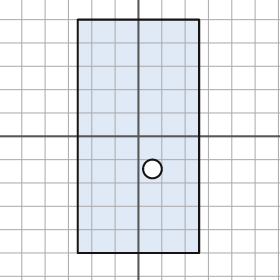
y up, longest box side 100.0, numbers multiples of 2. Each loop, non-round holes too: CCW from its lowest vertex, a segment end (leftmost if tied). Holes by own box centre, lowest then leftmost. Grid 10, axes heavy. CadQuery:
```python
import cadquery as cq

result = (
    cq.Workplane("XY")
    .moveTo(-26.0, -50.0)
    .lineTo(26.0, -50.0)
    .lineTo(26.0, 50.0)
    .lineTo(-26.0, 50.0)
    .close()
    .moveTo(6.0, -14.0)
    .circle(4.0)
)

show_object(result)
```